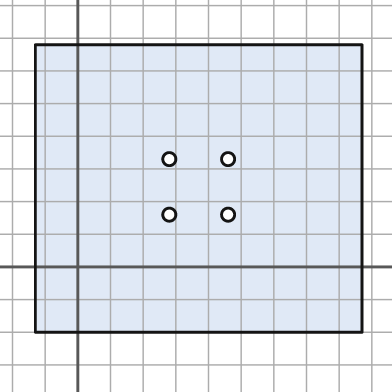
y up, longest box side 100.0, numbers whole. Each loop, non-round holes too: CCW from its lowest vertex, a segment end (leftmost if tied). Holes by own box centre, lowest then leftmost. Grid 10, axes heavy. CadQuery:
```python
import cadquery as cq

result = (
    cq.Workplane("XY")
    .moveTo(-13.0, -20.0)
    .lineTo(87.0, -20.0)
    .lineTo(87.0, 68.0)
    .lineTo(-13.0, 68.0)
    .close()
    .moveTo(28.0, 16.0)
    .circle(2.0)
    .moveTo(46.0, 16.0)
    .circle(2.0)
    .moveTo(28.0, 33.0)
    .circle(2.0)
    .moveTo(46.0, 33.0)
    .circle(2.0)
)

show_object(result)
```